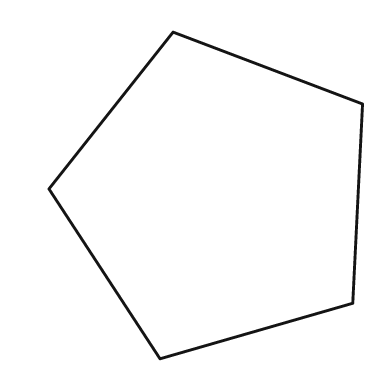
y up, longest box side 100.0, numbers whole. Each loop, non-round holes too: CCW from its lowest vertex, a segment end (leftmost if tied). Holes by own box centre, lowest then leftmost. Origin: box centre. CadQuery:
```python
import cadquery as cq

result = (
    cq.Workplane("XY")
    .moveTo(-14.0, -50.0)
    .lineTo(45.0, -33.0)
    .lineTo(48.0, 28.0)
    .lineTo(-10.0, 50.0)
    .lineTo(-48.0, 2.0)
    .close()
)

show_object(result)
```